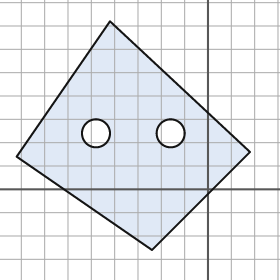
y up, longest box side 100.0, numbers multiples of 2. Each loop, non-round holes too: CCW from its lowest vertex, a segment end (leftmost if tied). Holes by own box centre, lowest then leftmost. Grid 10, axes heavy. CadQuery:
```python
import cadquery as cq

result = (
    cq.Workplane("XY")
    .moveTo(-24.0, -26.0)
    .lineTo(18.0, 16.0)
    .lineTo(-42.0, 72.0)
    .lineTo(-82.0, 14.0)
    .close()
    .moveTo(-48.0, 24.0)
    .circle(6.0)
    .moveTo(-16.0, 24.0)
    .circle(6.0)
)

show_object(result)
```